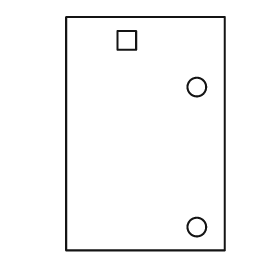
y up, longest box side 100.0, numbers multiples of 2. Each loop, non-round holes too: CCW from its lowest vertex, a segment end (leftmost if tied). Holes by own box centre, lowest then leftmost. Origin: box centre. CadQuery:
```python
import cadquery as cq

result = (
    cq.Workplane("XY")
    .moveTo(-34.0, -50.0)
    .lineTo(34.0, -50.0)
    .lineTo(34.0, 50.0)
    .lineTo(-34.0, 50.0)
    .close()
    .moveTo(22.0, -40.0)
    .circle(4.0)
    .moveTo(22.0, 20.0)
    .circle(4.0)
    .moveTo(-12.0, 36.0)
    .lineTo(-4.0, 36.0)
    .lineTo(-4.0, 44.0)
    .lineTo(-12.0, 44.0)
    .close()
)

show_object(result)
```